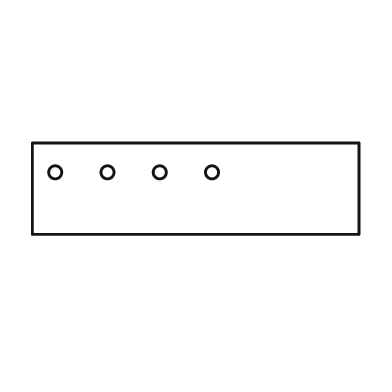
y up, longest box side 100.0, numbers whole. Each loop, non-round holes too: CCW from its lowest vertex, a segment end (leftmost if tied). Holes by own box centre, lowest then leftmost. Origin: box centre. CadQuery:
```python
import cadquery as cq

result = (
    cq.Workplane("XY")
    .moveTo(-50.0, -14.0)
    .lineTo(50.0, -14.0)
    .lineTo(50.0, 14.0)
    .lineTo(-50.0, 14.0)
    .close()
    .moveTo(-43.0, 5.0)
    .circle(2.0)
    .moveTo(-27.0, 5.0)
    .circle(2.0)
    .moveTo(-11.0, 5.0)
    .circle(2.0)
    .moveTo(5.0, 5.0)
    .circle(2.0)
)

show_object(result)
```